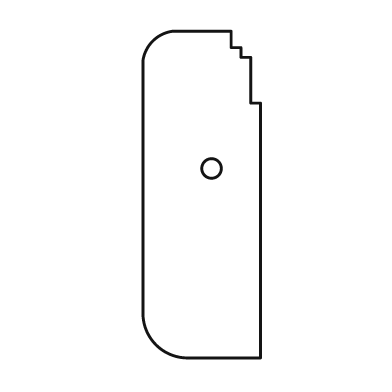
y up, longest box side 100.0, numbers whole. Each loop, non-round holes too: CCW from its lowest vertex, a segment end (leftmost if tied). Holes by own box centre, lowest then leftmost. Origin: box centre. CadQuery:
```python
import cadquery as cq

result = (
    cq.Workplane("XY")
    .moveTo(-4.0, -50.0)
    .lineTo(18.0, -50.0)
    .lineTo(18.0, 28.0)
    .lineTo(15.0, 28.0)
    .lineTo(15.0, 42.0)
    .lineTo(12.0, 42.0)
    .lineTo(12.0, 45.0)
    .lineTo(9.0, 45.0)
    .lineTo(9.0, 50.0)
    .lineTo(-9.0, 50.0)
    .threePointArc((-15.0, 47.0), (-18.0, 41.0))
    .lineTo(-18.0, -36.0)
    .threePointArc((-14.0, -46.0), (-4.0, -50.0))
    .close()
    .moveTo(3.0, 8.0)
    .circle(3.0)
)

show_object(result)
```